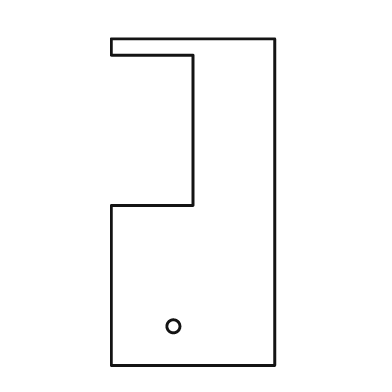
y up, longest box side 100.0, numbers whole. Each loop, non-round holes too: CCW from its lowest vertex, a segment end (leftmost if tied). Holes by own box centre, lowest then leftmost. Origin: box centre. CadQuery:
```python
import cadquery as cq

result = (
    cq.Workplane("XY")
    .moveTo(-25.0, -50.0)
    .lineTo(25.0, -50.0)
    .lineTo(25.0, 50.0)
    .lineTo(-25.0, 50.0)
    .lineTo(-25.0, 45.0)
    .lineTo(0.0, 45.0)
    .lineTo(0.0, -1.0)
    .lineTo(-25.0, -1.0)
    .close()
    .moveTo(-6.0, -38.0)
    .circle(2.0)
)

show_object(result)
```